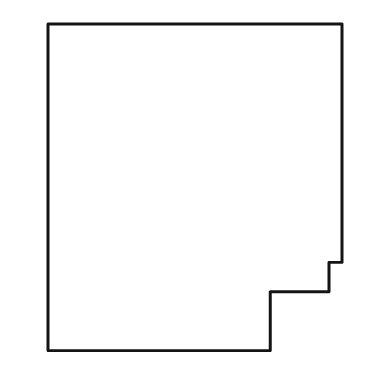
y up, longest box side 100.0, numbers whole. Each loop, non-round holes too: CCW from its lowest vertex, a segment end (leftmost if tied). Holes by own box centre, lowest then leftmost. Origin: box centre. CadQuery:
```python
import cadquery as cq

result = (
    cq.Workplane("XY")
    .moveTo(-45.0, -50.0)
    .lineTo(23.0, -50.0)
    .lineTo(23.0, -32.0)
    .lineTo(41.0, -32.0)
    .lineTo(41.0, -23.0)
    .lineTo(45.0, -23.0)
    .lineTo(45.0, 50.0)
    .lineTo(-45.0, 50.0)
    .close()
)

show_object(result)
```